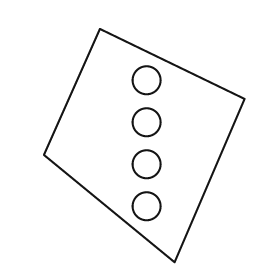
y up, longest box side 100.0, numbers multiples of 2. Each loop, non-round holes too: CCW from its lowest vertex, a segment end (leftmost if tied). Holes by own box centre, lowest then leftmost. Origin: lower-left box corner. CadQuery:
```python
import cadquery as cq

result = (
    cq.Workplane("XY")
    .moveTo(56.0, 0.0)
    .lineTo(86.0, 70.0)
    .lineTo(24.0, 100.0)
    .lineTo(0.0, 46.0)
    .close()
    .moveTo(44.0, 24.0)
    .circle(6.0)
    .moveTo(44.0, 42.0)
    .circle(6.0)
    .moveTo(44.0, 60.0)
    .circle(6.0)
    .moveTo(44.0, 78.0)
    .circle(6.0)
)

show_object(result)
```